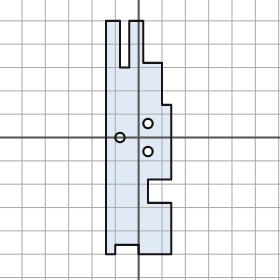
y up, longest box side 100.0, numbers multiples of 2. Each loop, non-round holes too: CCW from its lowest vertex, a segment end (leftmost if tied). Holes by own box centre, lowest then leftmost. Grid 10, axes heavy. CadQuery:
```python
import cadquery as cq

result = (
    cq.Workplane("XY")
    .moveTo(-14.0, -50.0)
    .lineTo(-10.0, -50.0)
    .lineTo(-10.0, -46.0)
    .lineTo(0.0, -46.0)
    .lineTo(0.0, -50.0)
    .lineTo(14.0, -50.0)
    .lineTo(14.0, -28.0)
    .lineTo(4.0, -28.0)
    .lineTo(4.0, -18.0)
    .lineTo(14.0, -18.0)
    .lineTo(14.0, 14.0)
    .lineTo(10.0, 14.0)
    .lineTo(10.0, 32.0)
    .lineTo(2.0, 32.0)
    .lineTo(2.0, 50.0)
    .lineTo(-4.0, 50.0)
    .lineTo(-4.0, 30.0)
    .lineTo(-8.0, 30.0)
    .lineTo(-8.0, 50.0)
    .lineTo(-14.0, 50.0)
    .close()
    .moveTo(4.0, -6.0)
    .circle(2.0)
    .moveTo(-8.0, 0.0)
    .circle(2.0)
    .moveTo(4.0, 6.0)
    .circle(2.0)
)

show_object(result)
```